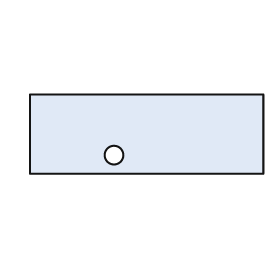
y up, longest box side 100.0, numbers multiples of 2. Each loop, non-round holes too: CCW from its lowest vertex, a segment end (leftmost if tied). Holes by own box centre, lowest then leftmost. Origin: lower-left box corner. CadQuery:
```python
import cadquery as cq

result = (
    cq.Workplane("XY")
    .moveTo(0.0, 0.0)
    .lineTo(100.0, 0.0)
    .lineTo(100.0, 34.0)
    .lineTo(0.0, 34.0)
    .close()
    .moveTo(36.0, 8.0)
    .circle(4.0)
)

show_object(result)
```